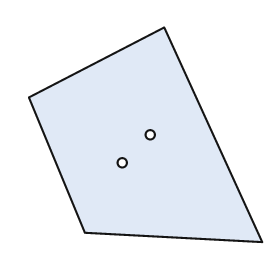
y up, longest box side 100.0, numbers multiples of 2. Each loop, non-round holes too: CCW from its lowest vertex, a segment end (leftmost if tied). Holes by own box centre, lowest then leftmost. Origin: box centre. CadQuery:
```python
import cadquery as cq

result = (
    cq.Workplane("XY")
    .moveTo(50.0, -46.0)
    .lineTo(8.0, 46.0)
    .lineTo(-50.0, 16.0)
    .lineTo(-26.0, -42.0)
    .close()
    .moveTo(-10.0, -12.0)
    .circle(2.0)
    .moveTo(2.0, 0.0)
    .circle(2.0)
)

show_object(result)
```